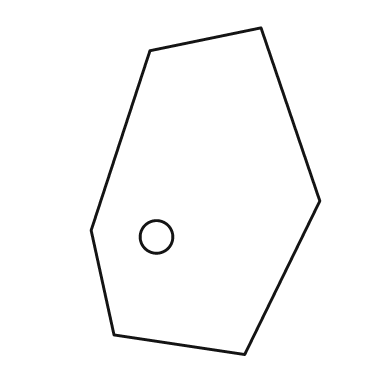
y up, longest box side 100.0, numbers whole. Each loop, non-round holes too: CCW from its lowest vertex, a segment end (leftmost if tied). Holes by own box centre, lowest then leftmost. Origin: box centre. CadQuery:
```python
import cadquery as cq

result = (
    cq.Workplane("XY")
    .moveTo(12.0, -50.0)
    .lineTo(35.0, -3.0)
    .lineTo(17.0, 50.0)
    .lineTo(-17.0, 43.0)
    .lineTo(-35.0, -12.0)
    .lineTo(-28.0, -44.0)
    .close()
    .moveTo(-15.0, -14.0)
    .circle(5.0)
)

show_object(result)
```